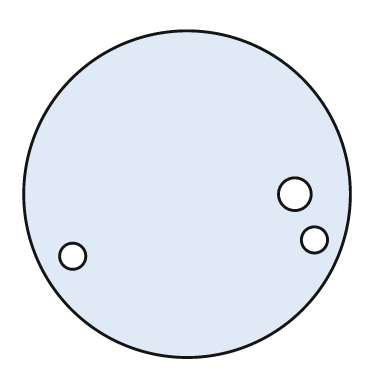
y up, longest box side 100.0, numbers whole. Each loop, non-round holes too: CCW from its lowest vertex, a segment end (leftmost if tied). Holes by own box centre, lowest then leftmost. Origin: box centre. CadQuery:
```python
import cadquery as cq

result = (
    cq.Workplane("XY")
    .moveTo(0.0, 0.0)
    .circle(50.0)
    .moveTo(-35.0, -19.0)
    .circle(4.0)
    .moveTo(39.0, -14.0)
    .circle(4.0)
    .moveTo(33.0, 0.0)
    .circle(5.0)
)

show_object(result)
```